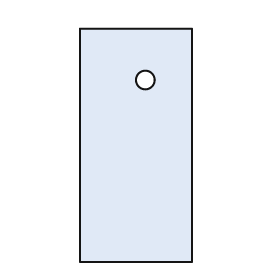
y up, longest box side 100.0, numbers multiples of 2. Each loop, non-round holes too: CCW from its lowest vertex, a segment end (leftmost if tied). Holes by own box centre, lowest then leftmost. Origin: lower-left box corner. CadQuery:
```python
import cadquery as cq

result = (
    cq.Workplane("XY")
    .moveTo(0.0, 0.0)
    .lineTo(48.0, 0.0)
    .lineTo(48.0, 100.0)
    .lineTo(0.0, 100.0)
    .close()
    .moveTo(28.0, 78.0)
    .circle(4.0)
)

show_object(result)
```